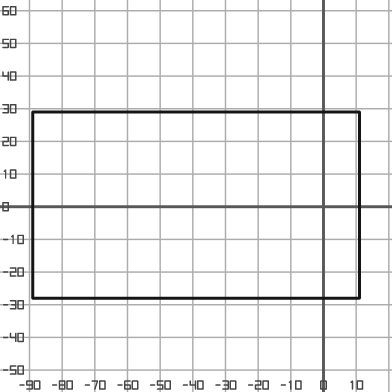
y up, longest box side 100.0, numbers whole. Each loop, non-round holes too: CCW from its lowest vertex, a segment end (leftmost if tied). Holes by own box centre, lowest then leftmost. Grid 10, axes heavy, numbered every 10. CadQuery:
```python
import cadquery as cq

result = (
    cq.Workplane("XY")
    .moveTo(-89.0, -28.0)
    .lineTo(11.0, -28.0)
    .lineTo(11.0, 29.0)
    .lineTo(-89.0, 29.0)
    .close()
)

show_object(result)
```